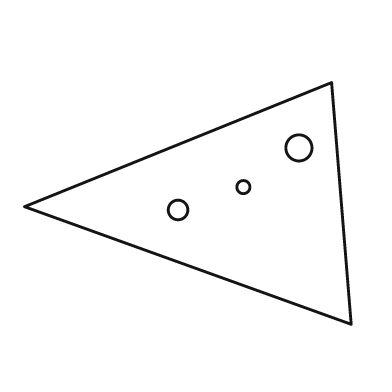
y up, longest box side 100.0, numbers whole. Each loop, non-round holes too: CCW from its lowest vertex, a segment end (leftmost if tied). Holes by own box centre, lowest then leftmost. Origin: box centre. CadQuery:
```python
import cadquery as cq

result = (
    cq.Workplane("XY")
    .moveTo(50.0, -37.0)
    .lineTo(44.0, 37.0)
    .lineTo(-50.0, -1.0)
    .close()
    .moveTo(-3.0, -2.0)
    .circle(3.0)
    .moveTo(17.0, 5.0)
    .circle(2.0)
    .moveTo(34.0, 17.0)
    .circle(4.0)
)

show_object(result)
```